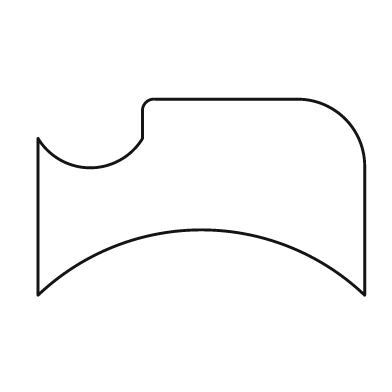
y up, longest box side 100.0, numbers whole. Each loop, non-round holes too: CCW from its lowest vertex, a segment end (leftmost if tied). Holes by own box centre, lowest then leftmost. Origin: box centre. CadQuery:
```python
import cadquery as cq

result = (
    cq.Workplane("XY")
    .moveTo(-50.0, -30.0)
    .threePointArc((0.0, -10.0), (50.0, -30.0))
    .lineTo(50.0, 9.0)
    .threePointArc((44.0, 24.0), (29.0, 30.0))
    .lineTo(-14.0, 30.0)
    .threePointArc((-17.0, 29.0), (-18.0, 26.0))
    .lineTo(-18.0, 18.0)
    .threePointArc((-34.0, 9.0), (-50.0, 18.0))
    .close()
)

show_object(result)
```